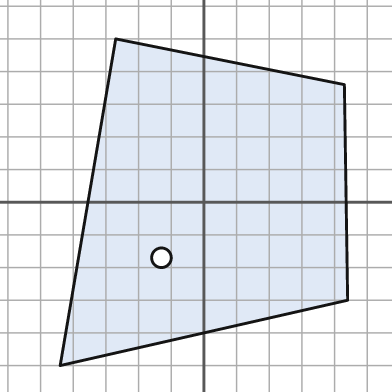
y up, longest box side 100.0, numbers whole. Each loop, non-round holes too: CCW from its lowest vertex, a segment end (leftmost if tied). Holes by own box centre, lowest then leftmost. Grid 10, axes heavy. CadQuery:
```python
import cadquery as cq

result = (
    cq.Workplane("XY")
    .moveTo(-44.0, -50.0)
    .lineTo(44.0, -30.0)
    .lineTo(43.0, 36.0)
    .lineTo(-27.0, 50.0)
    .close()
    .moveTo(-13.0, -17.0)
    .circle(3.0)
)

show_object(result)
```